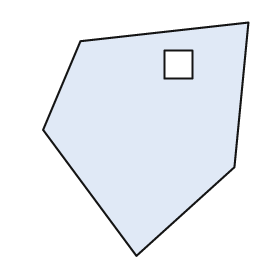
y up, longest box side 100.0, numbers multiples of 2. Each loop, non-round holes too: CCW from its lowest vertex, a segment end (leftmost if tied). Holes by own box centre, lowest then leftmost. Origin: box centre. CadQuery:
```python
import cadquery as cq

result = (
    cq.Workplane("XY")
    .moveTo(-4.0, -50.0)
    .lineTo(38.0, -12.0)
    .lineTo(44.0, 50.0)
    .lineTo(-28.0, 42.0)
    .lineTo(-44.0, 4.0)
    .close()
    .moveTo(8.0, 26.0)
    .lineTo(20.0, 26.0)
    .lineTo(20.0, 38.0)
    .lineTo(8.0, 38.0)
    .close()
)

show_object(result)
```